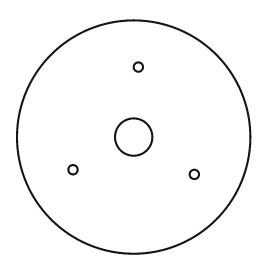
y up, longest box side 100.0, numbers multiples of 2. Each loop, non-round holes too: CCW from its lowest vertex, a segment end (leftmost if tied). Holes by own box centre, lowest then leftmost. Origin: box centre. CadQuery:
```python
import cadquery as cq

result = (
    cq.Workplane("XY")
    .moveTo(0.0, 0.0)
    .circle(50.0)
    .moveTo(26.0, -16.0)
    .circle(2.0)
    .moveTo(-26.0, -14.0)
    .circle(2.0)
    .moveTo(0.0, 0.0)
    .circle(8.0)
    .moveTo(2.0, 30.0)
    .circle(2.0)
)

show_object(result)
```